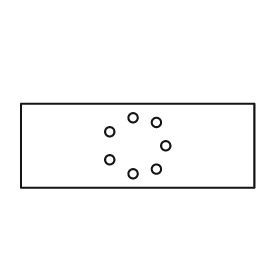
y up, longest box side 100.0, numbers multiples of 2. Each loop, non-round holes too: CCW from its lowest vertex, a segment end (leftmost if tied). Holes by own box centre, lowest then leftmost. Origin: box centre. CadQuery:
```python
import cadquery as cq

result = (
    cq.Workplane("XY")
    .moveTo(-50.0, -18.0)
    .lineTo(50.0, -18.0)
    .lineTo(50.0, 18.0)
    .lineTo(-50.0, 18.0)
    .close()
    .moveTo(-2.0, -12.0)
    .circle(2.0)
    .moveTo(8.0, -10.0)
    .circle(2.0)
    .moveTo(-12.0, -6.0)
    .circle(2.0)
    .moveTo(12.0, 0.0)
    .circle(2.0)
    .moveTo(-12.0, 6.0)
    .circle(2.0)
    .moveTo(8.0, 10.0)
    .circle(2.0)
    .moveTo(-2.0, 12.0)
    .circle(2.0)
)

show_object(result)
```